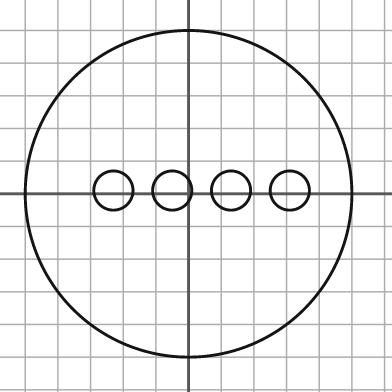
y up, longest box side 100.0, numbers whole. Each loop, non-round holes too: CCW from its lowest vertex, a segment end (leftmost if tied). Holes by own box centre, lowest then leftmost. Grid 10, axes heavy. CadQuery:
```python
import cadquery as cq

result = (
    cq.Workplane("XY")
    .moveTo(0.0, 0.0)
    .circle(50.0)
    .moveTo(-23.0, 1.0)
    .circle(6.0)
    .moveTo(-5.0, 1.0)
    .circle(6.0)
    .moveTo(13.0, 1.0)
    .circle(6.0)
    .moveTo(31.0, 1.0)
    .circle(6.0)
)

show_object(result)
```